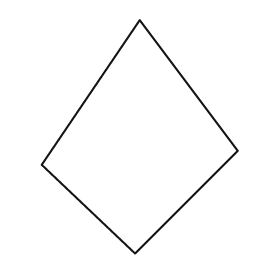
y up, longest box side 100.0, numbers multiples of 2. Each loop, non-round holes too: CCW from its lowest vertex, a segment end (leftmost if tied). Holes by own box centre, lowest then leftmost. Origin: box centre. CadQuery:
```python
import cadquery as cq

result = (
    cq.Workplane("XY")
    .moveTo(-2.0, -50.0)
    .lineTo(42.0, -6.0)
    .lineTo(0.0, 50.0)
    .lineTo(-42.0, -12.0)
    .close()
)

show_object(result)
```